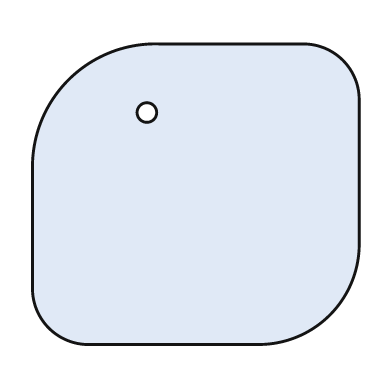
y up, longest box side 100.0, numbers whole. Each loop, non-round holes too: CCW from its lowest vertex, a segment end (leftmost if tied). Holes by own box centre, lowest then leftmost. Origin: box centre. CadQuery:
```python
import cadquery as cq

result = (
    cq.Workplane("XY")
    .moveTo(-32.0, -46.0)
    .lineTo(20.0, -46.0)
    .threePointArc((41.0, -37.0), (50.0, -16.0))
    .lineTo(50.0, 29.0)
    .threePointArc((45.0, 41.0), (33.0, 46.0))
    .lineTo(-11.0, 46.0)
    .threePointArc((-39.0, 35.0), (-50.0, 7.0))
    .lineTo(-50.0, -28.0)
    .threePointArc((-45.0, -41.0), (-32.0, -46.0))
    .close()
    .moveTo(-15.0, 25.0)
    .circle(3.0)
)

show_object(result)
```